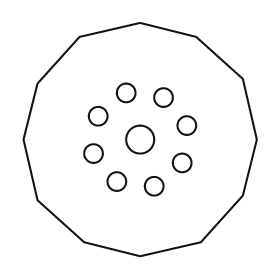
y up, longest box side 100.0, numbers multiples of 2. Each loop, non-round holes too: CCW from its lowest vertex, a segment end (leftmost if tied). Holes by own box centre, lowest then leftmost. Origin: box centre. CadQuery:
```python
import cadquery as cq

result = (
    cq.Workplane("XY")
    .moveTo(0.0, -50.0)
    .lineTo(26.0, -44.0)
    .lineTo(44.0, -24.0)
    .lineTo(50.0, 0.0)
    .lineTo(44.0, 26.0)
    .lineTo(24.0, 44.0)
    .lineTo(0.0, 50.0)
    .lineTo(-26.0, 44.0)
    .lineTo(-44.0, 24.0)
    .lineTo(-50.0, 0.0)
    .lineTo(-44.0, -26.0)
    .lineTo(-24.0, -44.0)
    .close()
    .moveTo(6.0, -20.0)
    .circle(4.0)
    .moveTo(-10.0, -18.0)
    .circle(4.0)
    .moveTo(18.0, -10.0)
    .circle(4.0)
    .moveTo(-20.0, -6.0)
    .circle(4.0)
    .moveTo(0.0, 0.0)
    .circle(6.0)
    .moveTo(20.0, 6.0)
    .circle(4.0)
    .moveTo(-18.0, 10.0)
    .circle(4.0)
    .moveTo(10.0, 18.0)
    .circle(4.0)
    .moveTo(-6.0, 20.0)
    .circle(4.0)
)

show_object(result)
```